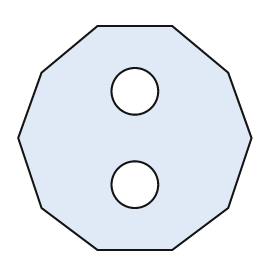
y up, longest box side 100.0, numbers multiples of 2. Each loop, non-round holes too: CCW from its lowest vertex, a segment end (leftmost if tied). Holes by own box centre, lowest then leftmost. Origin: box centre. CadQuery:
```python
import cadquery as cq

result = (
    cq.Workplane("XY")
    .moveTo(-16.0, -48.0)
    .lineTo(16.0, -48.0)
    .lineTo(40.0, -30.0)
    .lineTo(50.0, 0.0)
    .lineTo(40.0, 28.0)
    .lineTo(16.0, 48.0)
    .lineTo(-16.0, 48.0)
    .lineTo(-40.0, 28.0)
    .lineTo(-50.0, 0.0)
    .lineTo(-40.0, -30.0)
    .close()
    .moveTo(0.0, -20.0)
    .circle(10.0)
    .moveTo(0.0, 20.0)
    .circle(10.0)
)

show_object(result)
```